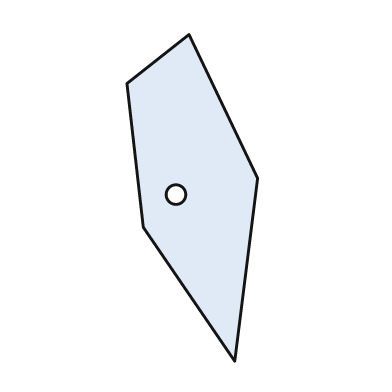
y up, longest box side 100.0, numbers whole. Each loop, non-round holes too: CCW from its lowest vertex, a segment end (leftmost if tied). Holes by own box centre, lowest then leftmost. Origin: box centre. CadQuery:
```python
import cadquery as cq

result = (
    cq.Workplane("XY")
    .moveTo(13.0, -50.0)
    .lineTo(20.0, 6.0)
    .lineTo(-1.0, 50.0)
    .lineTo(-20.0, 35.0)
    .lineTo(-15.0, -9.0)
    .close()
    .moveTo(-5.0, 1.0)
    .circle(3.0)
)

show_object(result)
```